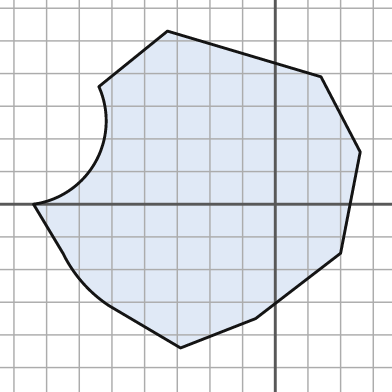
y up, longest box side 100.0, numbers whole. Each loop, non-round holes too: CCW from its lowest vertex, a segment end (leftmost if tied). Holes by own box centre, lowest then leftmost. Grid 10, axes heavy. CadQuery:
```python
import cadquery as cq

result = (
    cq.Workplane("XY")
    .moveTo(-29.0, -44.0)
    .lineTo(-6.0, -35.0)
    .lineTo(20.0, -15.0)
    .lineTo(26.0, 16.0)
    .lineTo(14.0, 39.0)
    .lineTo(-33.0, 53.0)
    .lineTo(-54.0, 36.0)
    .threePointArc((-55.0, 13.0), (-74.0, 0.0))
    .lineTo(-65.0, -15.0)
    .threePointArc((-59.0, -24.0), (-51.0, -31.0))
    .close()
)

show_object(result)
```